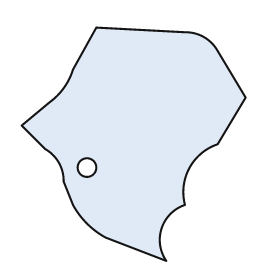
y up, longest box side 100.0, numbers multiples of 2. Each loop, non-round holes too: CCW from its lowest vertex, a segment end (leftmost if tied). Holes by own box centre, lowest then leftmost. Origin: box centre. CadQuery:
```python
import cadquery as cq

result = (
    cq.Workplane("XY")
    .moveTo(14.0, -50.0)
    .threePointArc((12.0, -36.0), (22.0, -26.0))
    .threePointArc((24.0, -10.0), (36.0, 0.0))
    .lineTo(48.0, 20.0)
    .lineTo(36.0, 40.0)
    .threePointArc((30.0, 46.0), (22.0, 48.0))
    .lineTo(-16.0, 50.0)
    .lineTo(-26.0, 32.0)
    .threePointArc((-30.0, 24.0), (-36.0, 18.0))
    .lineTo(-48.0, 8.0)
    .lineTo(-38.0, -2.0)
    .threePointArc((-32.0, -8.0), (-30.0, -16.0))
    .lineTo(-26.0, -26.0)
    .threePointArc((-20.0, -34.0), (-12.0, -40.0))
    .close()
    .moveTo(-20.0, -10.0)
    .circle(4.0)
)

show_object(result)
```